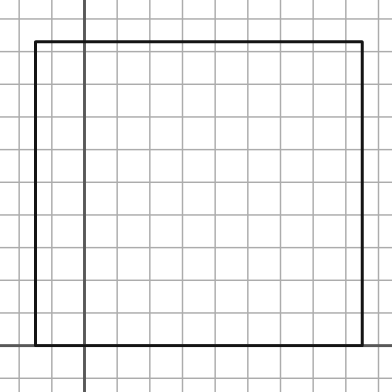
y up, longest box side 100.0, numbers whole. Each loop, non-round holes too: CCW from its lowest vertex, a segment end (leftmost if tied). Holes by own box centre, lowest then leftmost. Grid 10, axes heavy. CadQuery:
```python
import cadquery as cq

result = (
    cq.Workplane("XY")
    .moveTo(-15.0, 0.0)
    .lineTo(85.0, 0.0)
    .lineTo(85.0, 93.0)
    .lineTo(-15.0, 93.0)
    .close()
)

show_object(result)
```